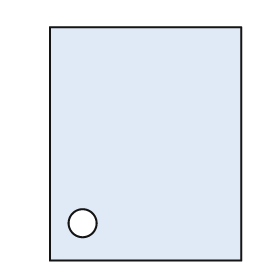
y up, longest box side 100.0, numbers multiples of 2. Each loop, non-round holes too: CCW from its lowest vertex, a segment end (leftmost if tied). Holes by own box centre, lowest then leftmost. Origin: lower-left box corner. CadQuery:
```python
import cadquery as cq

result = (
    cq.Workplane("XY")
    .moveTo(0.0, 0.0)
    .lineTo(82.0, 0.0)
    .lineTo(82.0, 100.0)
    .lineTo(0.0, 100.0)
    .close()
    .moveTo(14.0, 16.0)
    .circle(6.0)
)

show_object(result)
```